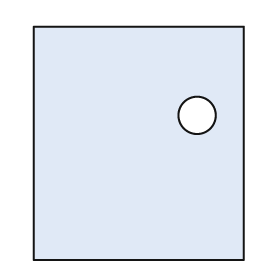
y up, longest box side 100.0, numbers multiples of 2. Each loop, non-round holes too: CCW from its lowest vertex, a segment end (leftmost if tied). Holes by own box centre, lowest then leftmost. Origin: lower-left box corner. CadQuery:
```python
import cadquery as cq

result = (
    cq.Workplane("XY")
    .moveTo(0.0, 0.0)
    .lineTo(90.0, 0.0)
    .lineTo(90.0, 100.0)
    .lineTo(0.0, 100.0)
    .close()
    .moveTo(70.0, 62.0)
    .circle(8.0)
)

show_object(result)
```